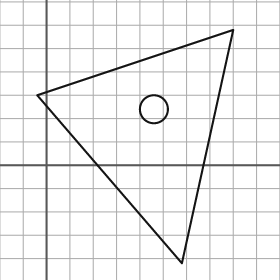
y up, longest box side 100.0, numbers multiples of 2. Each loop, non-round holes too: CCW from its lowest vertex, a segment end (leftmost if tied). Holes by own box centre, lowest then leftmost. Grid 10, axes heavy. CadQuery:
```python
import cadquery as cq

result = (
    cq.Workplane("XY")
    .moveTo(58.0, -42.0)
    .lineTo(80.0, 58.0)
    .lineTo(-4.0, 30.0)
    .close()
    .moveTo(46.0, 24.0)
    .circle(6.0)
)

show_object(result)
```